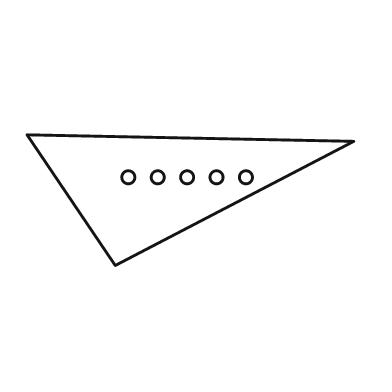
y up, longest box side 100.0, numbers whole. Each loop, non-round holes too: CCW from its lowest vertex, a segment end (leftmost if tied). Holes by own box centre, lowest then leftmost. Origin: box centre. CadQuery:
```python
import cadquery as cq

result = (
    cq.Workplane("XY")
    .moveTo(-23.0, -20.0)
    .lineTo(50.0, 18.0)
    .lineTo(-50.0, 20.0)
    .close()
    .moveTo(-19.0, 7.0)
    .circle(2.0)
    .moveTo(-10.0, 7.0)
    .circle(2.0)
    .moveTo(-1.0, 7.0)
    .circle(2.0)
    .moveTo(8.0, 7.0)
    .circle(2.0)
    .moveTo(17.0, 7.0)
    .circle(2.0)
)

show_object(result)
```